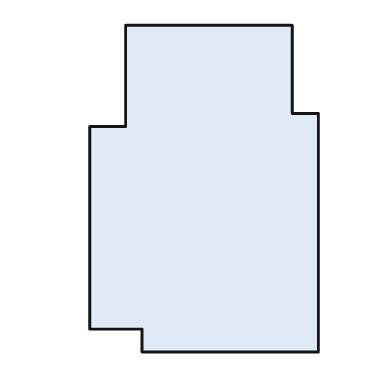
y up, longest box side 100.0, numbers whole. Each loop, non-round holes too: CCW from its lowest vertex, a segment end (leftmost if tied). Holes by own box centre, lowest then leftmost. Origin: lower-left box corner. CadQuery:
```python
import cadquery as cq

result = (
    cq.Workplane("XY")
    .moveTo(16.0, 0.0)
    .lineTo(70.0, 0.0)
    .lineTo(70.0, 73.0)
    .lineTo(62.0, 73.0)
    .lineTo(62.0, 100.0)
    .lineTo(11.0, 100.0)
    .lineTo(11.0, 69.0)
    .lineTo(0.0, 69.0)
    .lineTo(0.0, 7.0)
    .lineTo(16.0, 7.0)
    .close()
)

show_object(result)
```